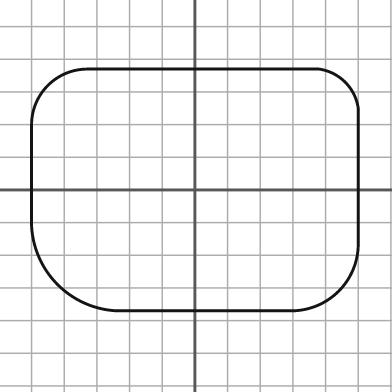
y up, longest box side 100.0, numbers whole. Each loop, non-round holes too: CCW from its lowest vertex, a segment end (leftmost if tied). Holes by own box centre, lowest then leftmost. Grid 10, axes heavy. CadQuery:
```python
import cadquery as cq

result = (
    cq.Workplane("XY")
    .moveTo(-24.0, -37.0)
    .lineTo(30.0, -37.0)
    .threePointArc((44.0, -31.0), (50.0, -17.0))
    .lineTo(50.0, 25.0)
    .threePointArc((46.0, 33.0), (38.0, 37.0))
    .lineTo(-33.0, 37.0)
    .threePointArc((-45.0, 32.0), (-50.0, 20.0))
    .lineTo(-50.0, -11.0)
    .threePointArc((-42.0, -29.0), (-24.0, -37.0))
    .close()
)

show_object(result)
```